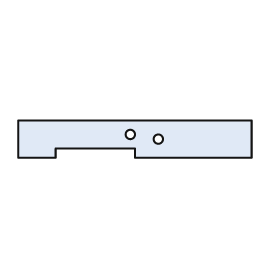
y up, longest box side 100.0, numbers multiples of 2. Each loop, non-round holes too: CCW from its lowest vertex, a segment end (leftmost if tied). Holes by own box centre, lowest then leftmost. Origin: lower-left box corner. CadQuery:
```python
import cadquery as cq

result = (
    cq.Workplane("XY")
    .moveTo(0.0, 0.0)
    .lineTo(16.0, 0.0)
    .lineTo(16.0, 4.0)
    .lineTo(50.0, 4.0)
    .lineTo(50.0, 0.0)
    .lineTo(100.0, 0.0)
    .lineTo(100.0, 16.0)
    .lineTo(0.0, 16.0)
    .close()
    .moveTo(60.0, 8.0)
    .circle(2.0)
    .moveTo(48.0, 10.0)
    .circle(2.0)
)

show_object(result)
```